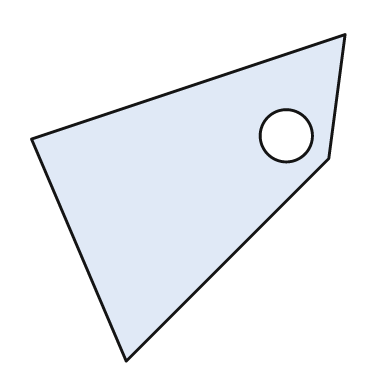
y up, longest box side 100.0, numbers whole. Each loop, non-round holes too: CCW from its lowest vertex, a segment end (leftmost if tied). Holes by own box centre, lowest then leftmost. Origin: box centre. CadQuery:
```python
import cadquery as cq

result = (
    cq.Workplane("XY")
    .moveTo(-19.0, -50.0)
    .lineTo(43.0, 12.0)
    .lineTo(48.0, 50.0)
    .lineTo(-48.0, 18.0)
    .close()
    .moveTo(30.0, 19.0)
    .circle(8.0)
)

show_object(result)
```